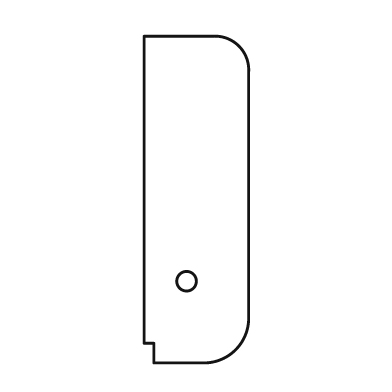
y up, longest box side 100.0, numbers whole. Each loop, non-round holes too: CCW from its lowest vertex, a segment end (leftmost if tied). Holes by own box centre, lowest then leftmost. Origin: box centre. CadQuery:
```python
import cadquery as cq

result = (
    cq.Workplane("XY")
    .moveTo(-13.0, -50.0)
    .lineTo(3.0, -50.0)
    .threePointArc((12.0, -46.0), (16.0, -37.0))
    .lineTo(16.0, 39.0)
    .threePointArc((13.0, 47.0), (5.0, 50.0))
    .lineTo(-16.0, 50.0)
    .lineTo(-16.0, -44.0)
    .lineTo(-13.0, -44.0)
    .close()
    .moveTo(-3.0, -25.0)
    .circle(3.0)
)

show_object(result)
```